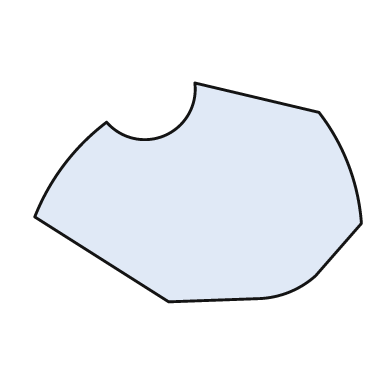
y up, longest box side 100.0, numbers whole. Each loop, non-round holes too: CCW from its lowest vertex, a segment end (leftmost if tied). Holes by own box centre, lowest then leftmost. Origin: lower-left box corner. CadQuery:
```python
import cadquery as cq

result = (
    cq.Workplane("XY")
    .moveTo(41.0, 0.0)
    .lineTo(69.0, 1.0)
    .threePointArc((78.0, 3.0), (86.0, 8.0))
    .lineTo(100.0, 24.0)
    .threePointArc((96.0, 42.0), (87.0, 58.0))
    .lineTo(49.0, 67.0)
    .threePointArc((40.0, 51.0), (22.0, 55.0))
    .threePointArc((9.0, 42.0), (0.0, 26.0))
    .close()
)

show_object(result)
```